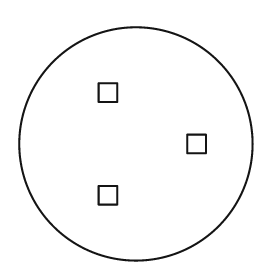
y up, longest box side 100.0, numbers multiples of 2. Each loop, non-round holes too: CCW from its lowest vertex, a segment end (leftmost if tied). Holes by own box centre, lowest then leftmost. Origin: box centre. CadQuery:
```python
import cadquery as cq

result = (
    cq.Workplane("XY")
    .moveTo(0.0, 0.0)
    .circle(50.0)
    .moveTo(-16.0, -26.0)
    .lineTo(-8.0, -26.0)
    .lineTo(-8.0, -18.0)
    .lineTo(-16.0, -18.0)
    .close()
    .moveTo(22.0, -4.0)
    .lineTo(30.0, -4.0)
    .lineTo(30.0, 4.0)
    .lineTo(22.0, 4.0)
    .close()
    .moveTo(-16.0, 18.0)
    .lineTo(-8.0, 18.0)
    .lineTo(-8.0, 26.0)
    .lineTo(-16.0, 26.0)
    .close()
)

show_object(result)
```